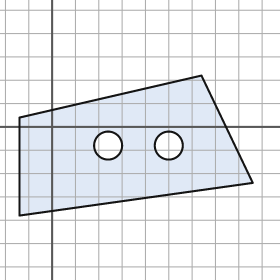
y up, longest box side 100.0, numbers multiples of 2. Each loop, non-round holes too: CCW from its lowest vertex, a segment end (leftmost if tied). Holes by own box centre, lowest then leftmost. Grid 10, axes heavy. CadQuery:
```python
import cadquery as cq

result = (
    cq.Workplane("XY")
    .moveTo(-14.0, -38.0)
    .lineTo(86.0, -24.0)
    .lineTo(64.0, 22.0)
    .lineTo(-14.0, 4.0)
    .close()
    .moveTo(24.0, -8.0)
    .circle(6.0)
    .moveTo(50.0, -8.0)
    .circle(6.0)
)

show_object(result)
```